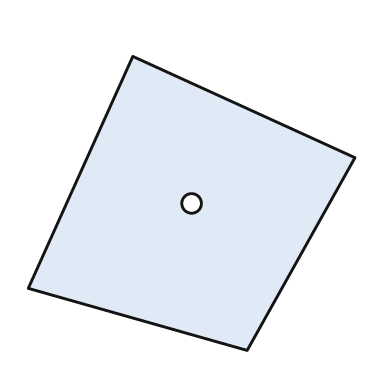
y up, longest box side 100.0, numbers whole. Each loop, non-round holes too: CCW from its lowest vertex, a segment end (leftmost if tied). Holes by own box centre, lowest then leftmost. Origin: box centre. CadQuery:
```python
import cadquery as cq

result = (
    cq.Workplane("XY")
    .moveTo(17.0, -45.0)
    .lineTo(50.0, 14.0)
    .lineTo(-18.0, 45.0)
    .lineTo(-50.0, -26.0)
    .close()
    .moveTo(0.0, 0.0)
    .circle(3.0)
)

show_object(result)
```